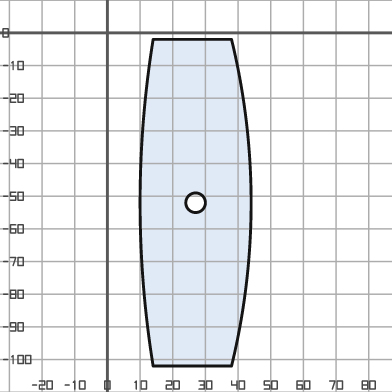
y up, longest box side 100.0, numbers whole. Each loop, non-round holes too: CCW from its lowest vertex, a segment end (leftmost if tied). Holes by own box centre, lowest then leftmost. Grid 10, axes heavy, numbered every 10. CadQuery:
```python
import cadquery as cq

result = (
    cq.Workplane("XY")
    .moveTo(14.0, -102.0)
    .lineTo(38.0, -102.0)
    .threePointArc((44.0, -52.0), (38.0, -2.0))
    .lineTo(14.0, -2.0)
    .threePointArc((10.0, -52.0), (14.0, -102.0))
    .close()
    .moveTo(27.0, -52.0)
    .circle(3.0)
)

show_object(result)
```